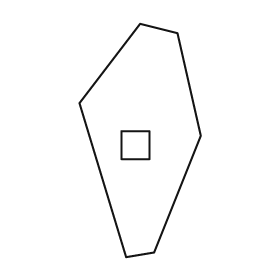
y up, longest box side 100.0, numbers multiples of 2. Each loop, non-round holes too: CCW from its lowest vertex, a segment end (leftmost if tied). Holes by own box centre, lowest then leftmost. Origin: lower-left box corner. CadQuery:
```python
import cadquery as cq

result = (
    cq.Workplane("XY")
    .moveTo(20.0, 0.0)
    .lineTo(32.0, 2.0)
    .lineTo(52.0, 52.0)
    .lineTo(42.0, 96.0)
    .lineTo(26.0, 100.0)
    .lineTo(0.0, 66.0)
    .close()
    .moveTo(18.0, 42.0)
    .lineTo(30.0, 42.0)
    .lineTo(30.0, 54.0)
    .lineTo(18.0, 54.0)
    .close()
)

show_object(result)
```